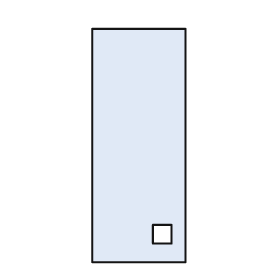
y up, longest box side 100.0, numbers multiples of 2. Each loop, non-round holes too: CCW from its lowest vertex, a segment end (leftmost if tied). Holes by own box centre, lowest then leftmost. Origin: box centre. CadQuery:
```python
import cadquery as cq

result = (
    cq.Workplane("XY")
    .moveTo(-20.0, -50.0)
    .lineTo(20.0, -50.0)
    .lineTo(20.0, 50.0)
    .lineTo(-20.0, 50.0)
    .close()
    .moveTo(6.0, -42.0)
    .lineTo(14.0, -42.0)
    .lineTo(14.0, -34.0)
    .lineTo(6.0, -34.0)
    .close()
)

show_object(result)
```